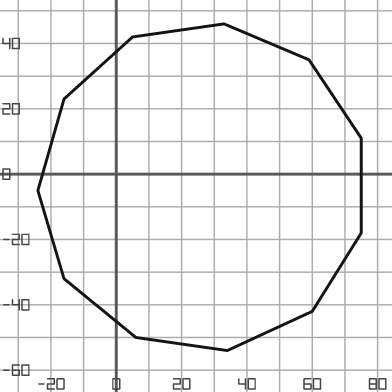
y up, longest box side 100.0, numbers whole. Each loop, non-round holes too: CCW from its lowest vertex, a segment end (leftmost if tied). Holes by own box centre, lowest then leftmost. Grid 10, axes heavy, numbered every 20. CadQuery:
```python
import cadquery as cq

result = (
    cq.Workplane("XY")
    .moveTo(34.0, -54.0)
    .lineTo(60.0, -42.0)
    .lineTo(75.0, -18.0)
    .lineTo(75.0, 11.0)
    .lineTo(59.0, 35.0)
    .lineTo(33.0, 46.0)
    .lineTo(5.0, 42.0)
    .lineTo(-16.0, 23.0)
    .lineTo(-24.0, -5.0)
    .lineTo(-16.0, -32.0)
    .lineTo(6.0, -50.0)
    .close()
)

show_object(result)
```